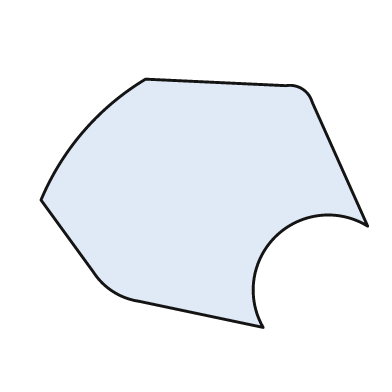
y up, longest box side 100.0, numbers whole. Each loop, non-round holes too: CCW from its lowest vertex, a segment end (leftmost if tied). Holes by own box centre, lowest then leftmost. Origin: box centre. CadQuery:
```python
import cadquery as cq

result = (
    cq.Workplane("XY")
    .moveTo(18.0, -38.0)
    .threePointArc((22.0, -10.0), (50.0, -7.0))
    .lineTo(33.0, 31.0)
    .threePointArc((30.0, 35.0), (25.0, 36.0))
    .lineTo(-18.0, 38.0)
    .threePointArc((-37.0, 22.0), (-50.0, 1.0))
    .lineTo(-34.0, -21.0)
    .threePointArc((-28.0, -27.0), (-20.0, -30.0))
    .close()
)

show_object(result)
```